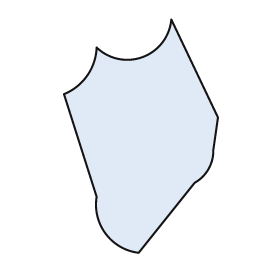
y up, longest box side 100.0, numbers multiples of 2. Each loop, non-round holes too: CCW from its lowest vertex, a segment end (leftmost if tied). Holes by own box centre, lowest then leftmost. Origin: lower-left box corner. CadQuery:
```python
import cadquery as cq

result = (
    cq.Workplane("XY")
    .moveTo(32.0, 0.0)
    .lineTo(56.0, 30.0)
    .threePointArc((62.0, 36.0), (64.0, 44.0))
    .lineTo(66.0, 58.0)
    .lineTo(46.0, 100.0)
    .threePointArc((34.0, 84.0), (14.0, 88.0))
    .threePointArc((10.0, 76.0), (0.0, 68.0))
    .lineTo(14.0, 24.0)
    .threePointArc((18.0, 8.0), (32.0, 0.0))
    .close()
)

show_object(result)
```